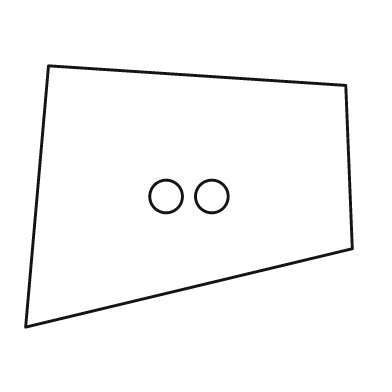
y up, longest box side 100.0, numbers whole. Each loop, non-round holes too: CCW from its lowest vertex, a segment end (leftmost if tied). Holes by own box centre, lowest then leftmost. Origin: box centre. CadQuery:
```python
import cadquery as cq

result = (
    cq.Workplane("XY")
    .moveTo(-50.0, -40.0)
    .lineTo(50.0, -16.0)
    .lineTo(48.0, 34.0)
    .lineTo(-43.0, 40.0)
    .close()
    .moveTo(-7.0, 0.0)
    .circle(5.0)
    .moveTo(7.0, 0.0)
    .circle(5.0)
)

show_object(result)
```